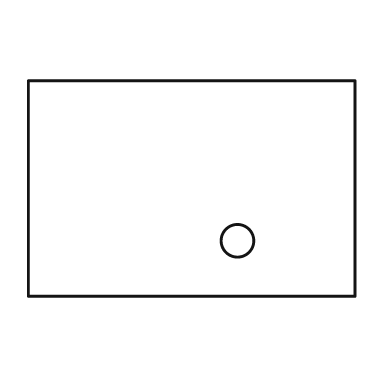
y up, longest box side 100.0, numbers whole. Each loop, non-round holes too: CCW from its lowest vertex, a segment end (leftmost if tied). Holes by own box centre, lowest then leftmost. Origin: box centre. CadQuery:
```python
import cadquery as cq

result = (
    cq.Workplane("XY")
    .moveTo(-50.0, -33.0)
    .lineTo(50.0, -33.0)
    .lineTo(50.0, 33.0)
    .lineTo(-50.0, 33.0)
    .close()
    .moveTo(14.0, -16.0)
    .circle(5.0)
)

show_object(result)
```